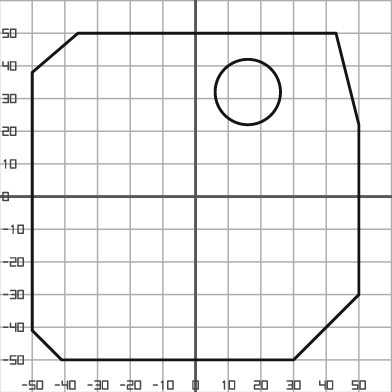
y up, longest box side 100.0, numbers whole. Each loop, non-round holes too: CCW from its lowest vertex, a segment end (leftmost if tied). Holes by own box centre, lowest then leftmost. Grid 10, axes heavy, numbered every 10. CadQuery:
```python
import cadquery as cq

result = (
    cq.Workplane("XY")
    .moveTo(-41.0, -50.0)
    .lineTo(30.0, -50.0)
    .lineTo(50.0, -30.0)
    .lineTo(50.0, 22.0)
    .lineTo(43.0, 50.0)
    .lineTo(-36.0, 50.0)
    .lineTo(-50.0, 38.0)
    .lineTo(-50.0, -41.0)
    .close()
    .moveTo(16.0, 32.0)
    .circle(10.0)
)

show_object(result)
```